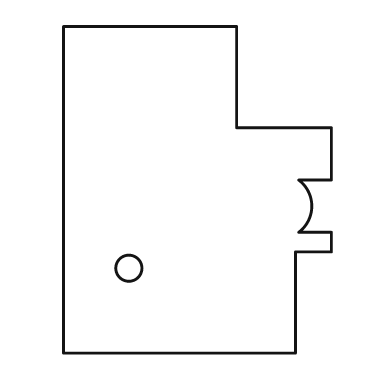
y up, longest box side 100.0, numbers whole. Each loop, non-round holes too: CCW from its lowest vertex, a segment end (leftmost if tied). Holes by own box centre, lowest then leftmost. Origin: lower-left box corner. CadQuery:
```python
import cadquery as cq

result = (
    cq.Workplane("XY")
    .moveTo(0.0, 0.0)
    .lineTo(71.0, 0.0)
    .lineTo(71.0, 31.0)
    .lineTo(82.0, 31.0)
    .lineTo(82.0, 37.0)
    .lineTo(72.0, 37.0)
    .threePointArc((76.0, 45.0), (72.0, 53.0))
    .lineTo(82.0, 53.0)
    .lineTo(82.0, 69.0)
    .lineTo(53.0, 69.0)
    .lineTo(53.0, 100.0)
    .lineTo(0.0, 100.0)
    .close()
    .moveTo(20.0, 26.0)
    .circle(4.0)
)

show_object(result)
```